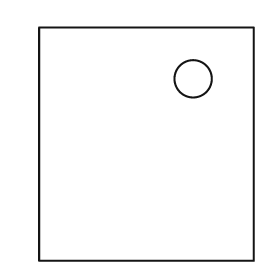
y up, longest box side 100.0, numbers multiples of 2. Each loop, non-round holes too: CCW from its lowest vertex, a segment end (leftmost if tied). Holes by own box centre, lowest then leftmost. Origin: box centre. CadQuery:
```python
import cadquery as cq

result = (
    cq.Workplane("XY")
    .moveTo(-46.0, -50.0)
    .lineTo(46.0, -50.0)
    .lineTo(46.0, 50.0)
    .lineTo(-46.0, 50.0)
    .close()
    .moveTo(20.0, 28.0)
    .circle(8.0)
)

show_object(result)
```